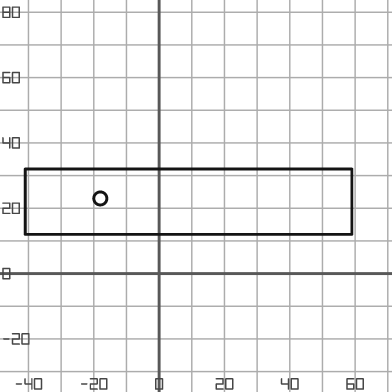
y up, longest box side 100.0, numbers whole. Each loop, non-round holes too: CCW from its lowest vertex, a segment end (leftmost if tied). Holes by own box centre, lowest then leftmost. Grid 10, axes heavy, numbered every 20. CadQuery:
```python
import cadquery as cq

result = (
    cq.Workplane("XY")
    .moveTo(-41.0, 12.0)
    .lineTo(59.0, 12.0)
    .lineTo(59.0, 32.0)
    .lineTo(-41.0, 32.0)
    .close()
    .moveTo(-18.0, 23.0)
    .circle(2.0)
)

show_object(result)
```